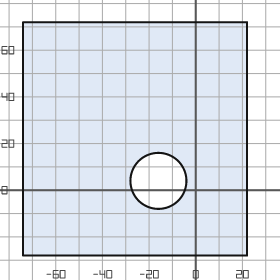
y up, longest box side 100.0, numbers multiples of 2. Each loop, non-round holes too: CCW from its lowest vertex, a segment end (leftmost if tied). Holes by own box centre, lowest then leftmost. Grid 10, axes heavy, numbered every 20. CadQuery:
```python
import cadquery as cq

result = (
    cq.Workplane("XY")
    .moveTo(-74.0, -28.0)
    .lineTo(22.0, -28.0)
    .lineTo(22.0, 72.0)
    .lineTo(-74.0, 72.0)
    .close()
    .moveTo(-16.0, 4.0)
    .circle(12.0)
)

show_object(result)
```